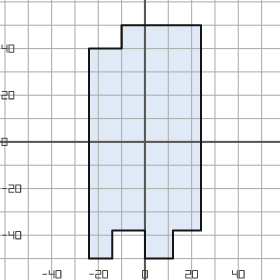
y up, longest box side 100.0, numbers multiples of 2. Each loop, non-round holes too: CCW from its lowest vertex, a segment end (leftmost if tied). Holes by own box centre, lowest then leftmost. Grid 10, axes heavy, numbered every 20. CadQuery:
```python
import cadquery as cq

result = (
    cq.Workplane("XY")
    .moveTo(-24.0, -50.0)
    .lineTo(-14.0, -50.0)
    .lineTo(-14.0, -38.0)
    .lineTo(0.0, -38.0)
    .lineTo(0.0, -50.0)
    .lineTo(12.0, -50.0)
    .lineTo(12.0, -38.0)
    .lineTo(24.0, -38.0)
    .lineTo(24.0, 50.0)
    .lineTo(-10.0, 50.0)
    .lineTo(-10.0, 40.0)
    .lineTo(-24.0, 40.0)
    .close()
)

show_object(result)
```